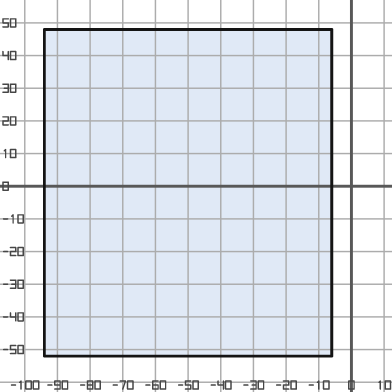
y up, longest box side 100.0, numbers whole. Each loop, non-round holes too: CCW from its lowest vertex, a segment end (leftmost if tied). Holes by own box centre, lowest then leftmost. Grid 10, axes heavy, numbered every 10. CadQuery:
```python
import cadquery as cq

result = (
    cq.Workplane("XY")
    .moveTo(-94.0, -52.0)
    .lineTo(-6.0, -52.0)
    .lineTo(-6.0, 48.0)
    .lineTo(-94.0, 48.0)
    .close()
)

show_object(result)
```